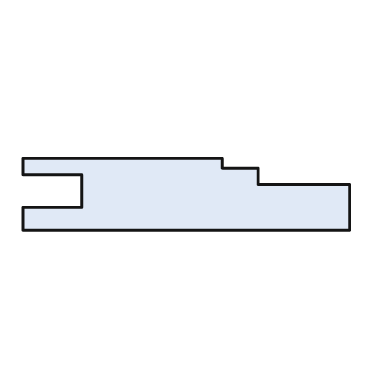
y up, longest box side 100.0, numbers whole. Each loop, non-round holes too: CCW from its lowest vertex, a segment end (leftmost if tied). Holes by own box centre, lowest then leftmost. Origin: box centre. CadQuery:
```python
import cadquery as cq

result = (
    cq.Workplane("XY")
    .moveTo(-50.0, -11.0)
    .lineTo(50.0, -11.0)
    .lineTo(50.0, 3.0)
    .lineTo(22.0, 3.0)
    .lineTo(22.0, 8.0)
    .lineTo(11.0, 8.0)
    .lineTo(11.0, 11.0)
    .lineTo(-50.0, 11.0)
    .lineTo(-50.0, 6.0)
    .lineTo(-32.0, 6.0)
    .lineTo(-32.0, -4.0)
    .lineTo(-50.0, -4.0)
    .close()
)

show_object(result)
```